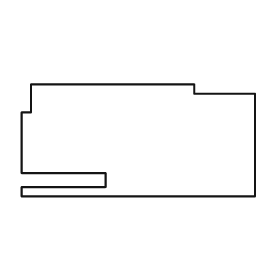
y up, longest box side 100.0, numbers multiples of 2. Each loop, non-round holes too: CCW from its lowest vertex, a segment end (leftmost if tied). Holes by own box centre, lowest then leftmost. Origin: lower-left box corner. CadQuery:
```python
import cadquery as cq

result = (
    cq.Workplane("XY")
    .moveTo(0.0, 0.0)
    .lineTo(100.0, 0.0)
    .lineTo(100.0, 44.0)
    .lineTo(74.0, 44.0)
    .lineTo(74.0, 48.0)
    .lineTo(4.0, 48.0)
    .lineTo(4.0, 36.0)
    .lineTo(0.0, 36.0)
    .lineTo(0.0, 10.0)
    .lineTo(36.0, 10.0)
    .lineTo(36.0, 4.0)
    .lineTo(0.0, 4.0)
    .close()
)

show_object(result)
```